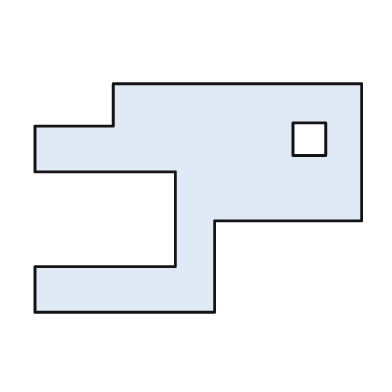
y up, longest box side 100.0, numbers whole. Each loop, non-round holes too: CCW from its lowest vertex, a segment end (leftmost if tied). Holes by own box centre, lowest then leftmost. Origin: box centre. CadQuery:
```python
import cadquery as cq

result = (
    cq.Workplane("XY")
    .moveTo(-50.0, -35.0)
    .lineTo(5.0, -35.0)
    .lineTo(5.0, -7.0)
    .lineTo(50.0, -7.0)
    .lineTo(50.0, 35.0)
    .lineTo(-26.0, 35.0)
    .lineTo(-26.0, 22.0)
    .lineTo(-50.0, 22.0)
    .lineTo(-50.0, 8.0)
    .lineTo(-7.0, 8.0)
    .lineTo(-7.0, -21.0)
    .lineTo(-50.0, -21.0)
    .close()
    .moveTo(29.0, 13.0)
    .lineTo(39.0, 13.0)
    .lineTo(39.0, 23.0)
    .lineTo(29.0, 23.0)
    .close()
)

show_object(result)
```